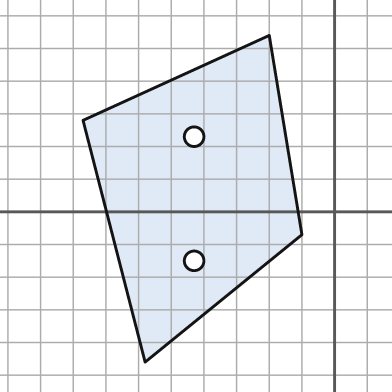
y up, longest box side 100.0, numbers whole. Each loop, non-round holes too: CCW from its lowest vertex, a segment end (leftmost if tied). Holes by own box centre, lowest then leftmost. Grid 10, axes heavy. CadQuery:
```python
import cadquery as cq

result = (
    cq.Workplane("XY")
    .moveTo(-58.0, -46.0)
    .lineTo(-10.0, -7.0)
    .lineTo(-20.0, 54.0)
    .lineTo(-77.0, 28.0)
    .close()
    .moveTo(-43.0, -15.0)
    .circle(3.0)
    .moveTo(-43.0, 23.0)
    .circle(3.0)
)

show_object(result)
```